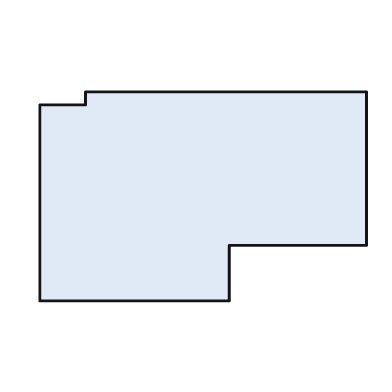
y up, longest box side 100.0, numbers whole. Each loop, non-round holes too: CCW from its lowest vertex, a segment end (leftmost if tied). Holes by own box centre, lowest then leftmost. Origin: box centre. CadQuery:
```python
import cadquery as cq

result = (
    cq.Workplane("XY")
    .moveTo(-50.0, -32.0)
    .lineTo(8.0, -32.0)
    .lineTo(8.0, -15.0)
    .lineTo(50.0, -15.0)
    .lineTo(50.0, 32.0)
    .lineTo(-36.0, 32.0)
    .lineTo(-36.0, 28.0)
    .lineTo(-50.0, 28.0)
    .close()
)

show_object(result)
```